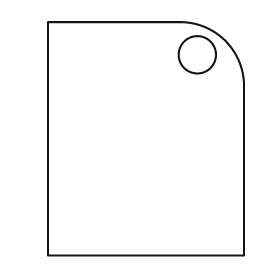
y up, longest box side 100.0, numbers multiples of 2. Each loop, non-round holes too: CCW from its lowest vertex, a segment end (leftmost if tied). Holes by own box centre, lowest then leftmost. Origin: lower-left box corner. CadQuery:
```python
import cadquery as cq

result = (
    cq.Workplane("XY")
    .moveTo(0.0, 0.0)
    .lineTo(84.0, 0.0)
    .lineTo(84.0, 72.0)
    .threePointArc((76.0, 92.0), (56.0, 100.0))
    .lineTo(0.0, 100.0)
    .close()
    .moveTo(64.0, 86.0)
    .circle(8.0)
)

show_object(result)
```